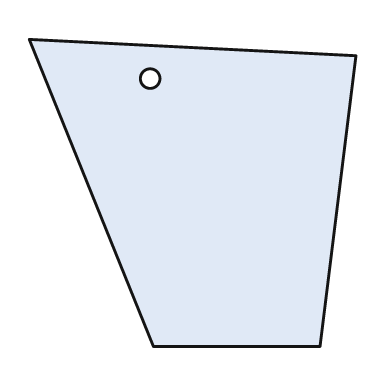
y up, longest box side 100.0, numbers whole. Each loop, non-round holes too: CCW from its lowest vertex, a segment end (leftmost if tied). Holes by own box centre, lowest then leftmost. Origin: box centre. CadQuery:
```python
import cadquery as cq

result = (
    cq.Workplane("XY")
    .moveTo(-12.0, -47.0)
    .lineTo(39.0, -47.0)
    .lineTo(50.0, 42.0)
    .lineTo(-50.0, 47.0)
    .close()
    .moveTo(-13.0, 35.0)
    .circle(3.0)
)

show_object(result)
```